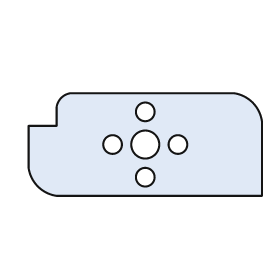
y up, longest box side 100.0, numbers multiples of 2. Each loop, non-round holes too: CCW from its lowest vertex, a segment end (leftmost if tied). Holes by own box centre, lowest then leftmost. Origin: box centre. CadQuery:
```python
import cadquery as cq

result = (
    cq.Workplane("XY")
    .moveTo(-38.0, -22.0)
    .lineTo(50.0, -22.0)
    .lineTo(50.0, 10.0)
    .threePointArc((46.0, 18.0), (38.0, 22.0))
    .lineTo(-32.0, 22.0)
    .threePointArc((-36.0, 20.0), (-38.0, 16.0))
    .lineTo(-38.0, 8.0)
    .lineTo(-50.0, 8.0)
    .lineTo(-50.0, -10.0)
    .threePointArc((-46.0, -18.0), (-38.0, -22.0))
    .close()
    .moveTo(0.0, -14.0)
    .circle(4.0)
    .moveTo(-14.0, 0.0)
    .circle(4.0)
    .moveTo(0.0, 0.0)
    .circle(6.0)
    .moveTo(14.0, 0.0)
    .circle(4.0)
    .moveTo(0.0, 14.0)
    .circle(4.0)
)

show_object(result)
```